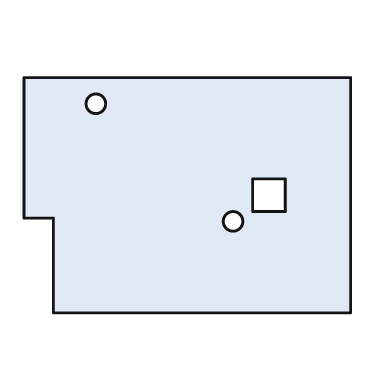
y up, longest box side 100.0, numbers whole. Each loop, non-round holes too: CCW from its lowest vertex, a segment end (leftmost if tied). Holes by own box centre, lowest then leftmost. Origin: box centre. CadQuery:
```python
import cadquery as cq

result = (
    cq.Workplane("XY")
    .moveTo(-41.0, -36.0)
    .lineTo(50.0, -36.0)
    .lineTo(50.0, 36.0)
    .lineTo(-50.0, 36.0)
    .lineTo(-50.0, -7.0)
    .lineTo(-41.0, -7.0)
    .close()
    .moveTo(14.0, -8.0)
    .circle(3.0)
    .moveTo(20.0, -5.0)
    .lineTo(30.0, -5.0)
    .lineTo(30.0, 5.0)
    .lineTo(20.0, 5.0)
    .close()
    .moveTo(-28.0, 28.0)
    .circle(3.0)
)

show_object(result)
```